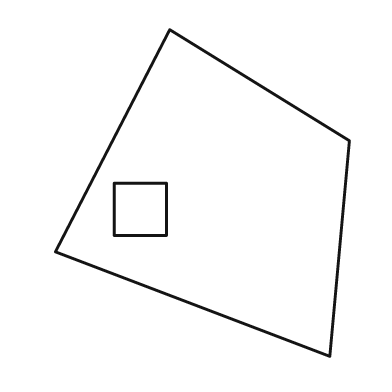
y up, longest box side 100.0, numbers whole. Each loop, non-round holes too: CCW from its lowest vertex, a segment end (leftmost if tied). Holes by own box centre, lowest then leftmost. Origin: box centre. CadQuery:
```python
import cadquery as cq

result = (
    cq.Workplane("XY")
    .moveTo(39.0, -50.0)
    .lineTo(45.0, 16.0)
    .lineTo(-10.0, 50.0)
    .lineTo(-45.0, -18.0)
    .close()
    .moveTo(-27.0, -13.0)
    .lineTo(-11.0, -13.0)
    .lineTo(-11.0, 3.0)
    .lineTo(-27.0, 3.0)
    .close()
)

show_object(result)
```